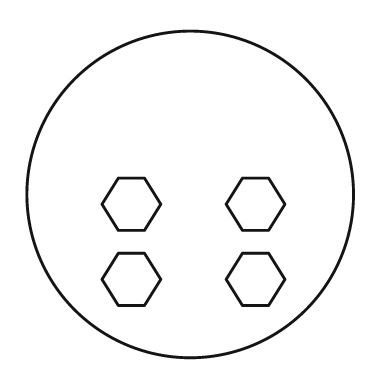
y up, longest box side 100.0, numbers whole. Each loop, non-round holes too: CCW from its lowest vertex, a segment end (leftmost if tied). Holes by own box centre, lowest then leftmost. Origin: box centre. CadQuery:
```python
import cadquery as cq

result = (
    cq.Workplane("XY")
    .moveTo(0.0, 0.0)
    .circle(50.0)
    .moveTo(-22.0, -34.0)
    .lineTo(-14.0, -34.0)
    .lineTo(-9.0, -26.0)
    .lineTo(-14.0, -18.0)
    .lineTo(-22.0, -18.0)
    .lineTo(-27.0, -26.0)
    .close()
    .moveTo(16.0, -34.0)
    .lineTo(24.0, -34.0)
    .lineTo(29.0, -26.0)
    .lineTo(24.0, -18.0)
    .lineTo(16.0, -18.0)
    .lineTo(11.0, -26.0)
    .close()
    .moveTo(-22.0, -11.0)
    .lineTo(-14.0, -11.0)
    .lineTo(-9.0, -3.0)
    .lineTo(-14.0, 5.0)
    .lineTo(-22.0, 5.0)
    .lineTo(-27.0, -3.0)
    .close()
    .moveTo(16.0, -11.0)
    .lineTo(24.0, -11.0)
    .lineTo(29.0, -3.0)
    .lineTo(24.0, 5.0)
    .lineTo(16.0, 5.0)
    .lineTo(11.0, -3.0)
    .close()
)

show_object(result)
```